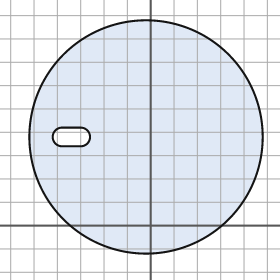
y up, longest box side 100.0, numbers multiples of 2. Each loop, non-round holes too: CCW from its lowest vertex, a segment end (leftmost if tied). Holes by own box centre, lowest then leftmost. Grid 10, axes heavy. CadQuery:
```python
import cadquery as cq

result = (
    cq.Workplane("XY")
    .moveTo(-2.0, 38.0)
    .circle(50.0)
    .moveTo(-38.0, 34.0)
    .lineTo(-30.0, 34.0)
    .threePointArc((-26.0, 38.0), (-30.0, 42.0))
    .lineTo(-38.0, 42.0)
    .threePointArc((-42.0, 38.0), (-38.0, 34.0))
    .close()
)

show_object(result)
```